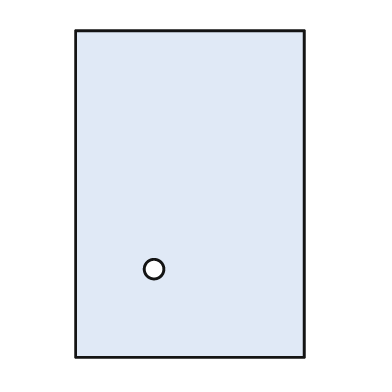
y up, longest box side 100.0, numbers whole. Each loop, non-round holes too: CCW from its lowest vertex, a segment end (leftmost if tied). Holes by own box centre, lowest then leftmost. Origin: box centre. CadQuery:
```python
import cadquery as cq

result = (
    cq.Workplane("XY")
    .moveTo(-35.0, -50.0)
    .lineTo(35.0, -50.0)
    .lineTo(35.0, 50.0)
    .lineTo(-35.0, 50.0)
    .close()
    .moveTo(-11.0, -23.0)
    .circle(3.0)
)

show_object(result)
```